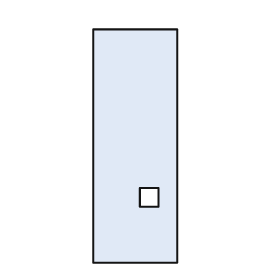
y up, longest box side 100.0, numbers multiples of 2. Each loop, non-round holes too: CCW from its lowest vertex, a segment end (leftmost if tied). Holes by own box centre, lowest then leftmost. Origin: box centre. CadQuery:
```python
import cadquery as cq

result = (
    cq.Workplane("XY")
    .moveTo(-18.0, -50.0)
    .lineTo(18.0, -50.0)
    .lineTo(18.0, 50.0)
    .lineTo(-18.0, 50.0)
    .close()
    .moveTo(2.0, -26.0)
    .lineTo(10.0, -26.0)
    .lineTo(10.0, -18.0)
    .lineTo(2.0, -18.0)
    .close()
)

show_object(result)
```